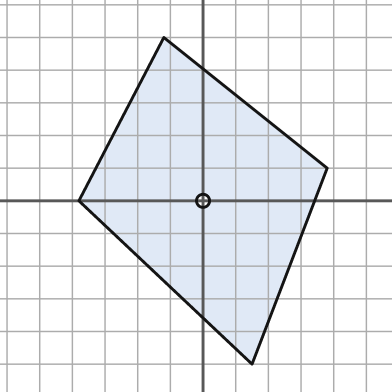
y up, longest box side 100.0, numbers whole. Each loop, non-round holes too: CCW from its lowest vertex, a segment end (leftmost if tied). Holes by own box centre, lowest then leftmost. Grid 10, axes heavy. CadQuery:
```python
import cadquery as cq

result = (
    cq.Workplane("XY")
    .moveTo(15.0, -50.0)
    .lineTo(38.0, 10.0)
    .lineTo(-12.0, 50.0)
    .lineTo(-38.0, 0.0)
    .close()
    .moveTo(0.0, 0.0)
    .circle(2.0)
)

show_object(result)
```